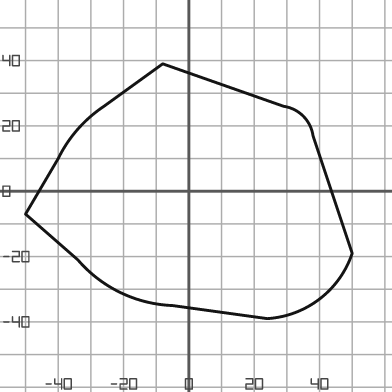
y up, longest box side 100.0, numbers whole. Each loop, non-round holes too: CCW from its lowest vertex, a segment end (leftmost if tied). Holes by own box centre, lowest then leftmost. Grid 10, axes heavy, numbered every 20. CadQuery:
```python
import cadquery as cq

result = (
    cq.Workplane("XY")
    .moveTo(24.0, -39.0)
    .threePointArc((40.0, -33.0), (50.0, -19.0))
    .lineTo(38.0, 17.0)
    .threePointArc((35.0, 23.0), (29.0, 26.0))
    .lineTo(-8.0, 39.0)
    .lineTo(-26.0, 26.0)
    .threePointArc((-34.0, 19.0), (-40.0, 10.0))
    .lineTo(-50.0, -7.0)
    .lineTo(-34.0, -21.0)
    .threePointArc((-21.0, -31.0), (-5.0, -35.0))
    .close()
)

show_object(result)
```